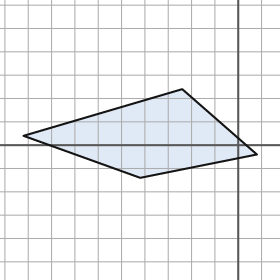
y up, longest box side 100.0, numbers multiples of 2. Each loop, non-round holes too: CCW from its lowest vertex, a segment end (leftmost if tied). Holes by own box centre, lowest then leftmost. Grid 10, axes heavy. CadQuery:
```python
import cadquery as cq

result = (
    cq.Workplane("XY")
    .moveTo(-42.0, -14.0)
    .lineTo(8.0, -4.0)
    .lineTo(-24.0, 24.0)
    .lineTo(-92.0, 4.0)
    .close()
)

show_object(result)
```